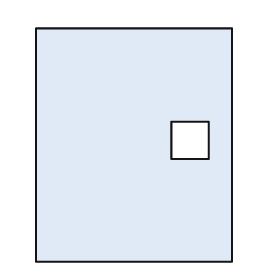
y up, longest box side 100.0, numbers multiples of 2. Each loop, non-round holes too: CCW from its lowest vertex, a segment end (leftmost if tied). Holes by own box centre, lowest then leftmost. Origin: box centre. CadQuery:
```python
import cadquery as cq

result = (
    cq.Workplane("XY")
    .moveTo(-42.0, -50.0)
    .lineTo(42.0, -50.0)
    .lineTo(42.0, 50.0)
    .lineTo(-42.0, 50.0)
    .close()
    .moveTo(16.0, -6.0)
    .lineTo(32.0, -6.0)
    .lineTo(32.0, 10.0)
    .lineTo(16.0, 10.0)
    .close()
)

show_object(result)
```